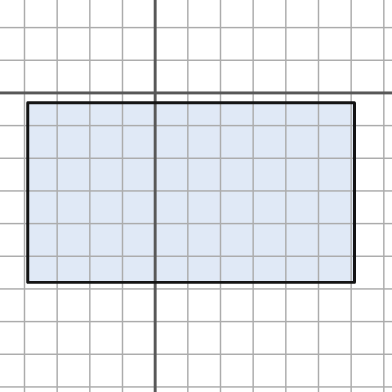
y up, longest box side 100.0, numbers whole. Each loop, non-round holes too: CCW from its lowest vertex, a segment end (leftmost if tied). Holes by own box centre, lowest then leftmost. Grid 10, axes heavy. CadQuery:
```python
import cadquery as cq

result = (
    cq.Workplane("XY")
    .moveTo(-39.0, -58.0)
    .lineTo(61.0, -58.0)
    .lineTo(61.0, -3.0)
    .lineTo(-39.0, -3.0)
    .close()
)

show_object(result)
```